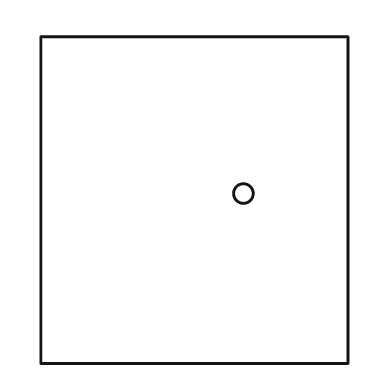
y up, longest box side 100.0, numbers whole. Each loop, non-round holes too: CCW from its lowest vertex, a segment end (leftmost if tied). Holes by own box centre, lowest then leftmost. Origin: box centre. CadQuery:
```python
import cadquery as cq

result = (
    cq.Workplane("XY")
    .moveTo(-47.0, -50.0)
    .lineTo(47.0, -50.0)
    .lineTo(47.0, 50.0)
    .lineTo(-47.0, 50.0)
    .close()
    .moveTo(15.0, 2.0)
    .circle(3.0)
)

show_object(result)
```